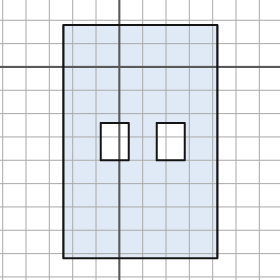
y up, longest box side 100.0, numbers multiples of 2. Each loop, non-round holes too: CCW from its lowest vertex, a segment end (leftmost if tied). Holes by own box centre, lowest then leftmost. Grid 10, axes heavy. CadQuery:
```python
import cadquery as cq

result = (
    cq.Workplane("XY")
    .moveTo(-24.0, -82.0)
    .lineTo(42.0, -82.0)
    .lineTo(42.0, 18.0)
    .lineTo(-24.0, 18.0)
    .close()
    .moveTo(-8.0, -40.0)
    .lineTo(4.0, -40.0)
    .lineTo(4.0, -24.0)
    .lineTo(-8.0, -24.0)
    .close()
    .moveTo(16.0, -40.0)
    .lineTo(28.0, -40.0)
    .lineTo(28.0, -24.0)
    .lineTo(16.0, -24.0)
    .close()
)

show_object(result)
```